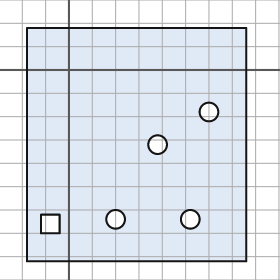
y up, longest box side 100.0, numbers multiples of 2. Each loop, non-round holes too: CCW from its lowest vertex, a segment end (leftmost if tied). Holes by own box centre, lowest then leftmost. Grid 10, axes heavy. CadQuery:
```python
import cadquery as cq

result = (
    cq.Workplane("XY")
    .moveTo(-18.0, -82.0)
    .lineTo(76.0, -82.0)
    .lineTo(76.0, 18.0)
    .lineTo(-18.0, 18.0)
    .close()
    .moveTo(-12.0, -70.0)
    .lineTo(-4.0, -70.0)
    .lineTo(-4.0, -62.0)
    .lineTo(-12.0, -62.0)
    .close()
    .moveTo(20.0, -64.0)
    .circle(4.0)
    .moveTo(52.0, -64.0)
    .circle(4.0)
    .moveTo(38.0, -32.0)
    .circle(4.0)
    .moveTo(60.0, -18.0)
    .circle(4.0)
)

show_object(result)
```